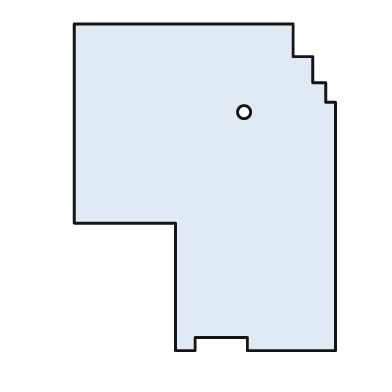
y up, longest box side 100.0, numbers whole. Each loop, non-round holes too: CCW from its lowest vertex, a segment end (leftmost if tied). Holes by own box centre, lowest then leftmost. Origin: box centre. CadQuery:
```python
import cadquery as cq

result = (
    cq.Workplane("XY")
    .moveTo(-9.0, -50.0)
    .lineTo(-3.0, -50.0)
    .lineTo(-3.0, -46.0)
    .lineTo(13.0, -46.0)
    .lineTo(13.0, -50.0)
    .lineTo(40.0, -50.0)
    .lineTo(40.0, 26.0)
    .lineTo(37.0, 26.0)
    .lineTo(37.0, 32.0)
    .lineTo(33.0, 32.0)
    .lineTo(33.0, 40.0)
    .lineTo(27.0, 40.0)
    .lineTo(27.0, 50.0)
    .lineTo(-40.0, 50.0)
    .lineTo(-40.0, -11.0)
    .lineTo(-9.0, -11.0)
    .close()
    .moveTo(12.0, 23.0)
    .circle(2.0)
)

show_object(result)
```